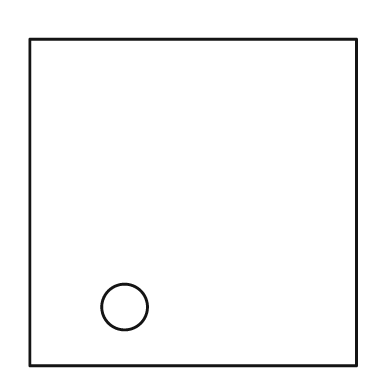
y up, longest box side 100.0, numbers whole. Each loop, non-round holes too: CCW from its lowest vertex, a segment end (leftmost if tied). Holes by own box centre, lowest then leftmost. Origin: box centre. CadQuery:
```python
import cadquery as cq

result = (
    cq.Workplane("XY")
    .moveTo(-50.0, -50.0)
    .lineTo(50.0, -50.0)
    .lineTo(50.0, 50.0)
    .lineTo(-50.0, 50.0)
    .close()
    .moveTo(-21.0, -32.0)
    .circle(7.0)
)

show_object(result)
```